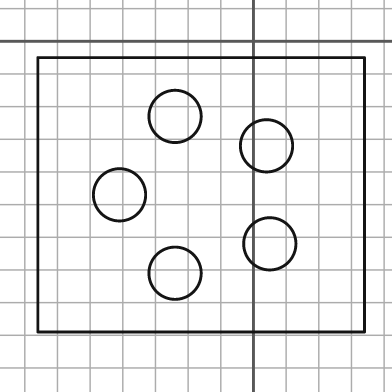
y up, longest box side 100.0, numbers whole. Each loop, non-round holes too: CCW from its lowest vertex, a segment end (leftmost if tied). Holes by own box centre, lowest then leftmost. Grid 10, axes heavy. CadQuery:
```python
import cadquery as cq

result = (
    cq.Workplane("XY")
    .moveTo(-66.0, -89.0)
    .lineTo(34.0, -89.0)
    .lineTo(34.0, -5.0)
    .lineTo(-66.0, -5.0)
    .close()
    .moveTo(-24.0, -71.0)
    .circle(8.0)
    .moveTo(5.0, -62.0)
    .circle(8.0)
    .moveTo(-41.0, -47.0)
    .circle(8.0)
    .moveTo(4.0, -32.0)
    .circle(8.0)
    .moveTo(-24.0, -23.0)
    .circle(8.0)
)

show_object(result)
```